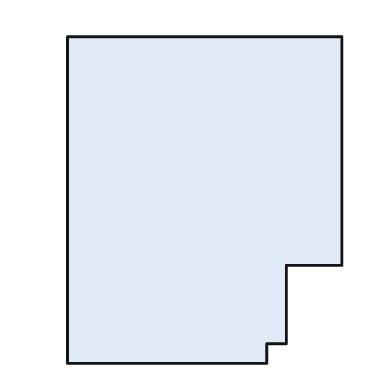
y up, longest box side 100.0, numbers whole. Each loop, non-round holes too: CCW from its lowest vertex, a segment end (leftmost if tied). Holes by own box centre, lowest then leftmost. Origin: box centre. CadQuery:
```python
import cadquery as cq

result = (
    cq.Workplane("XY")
    .moveTo(-42.0, -50.0)
    .lineTo(19.0, -50.0)
    .lineTo(19.0, -44.0)
    .lineTo(25.0, -44.0)
    .lineTo(25.0, -20.0)
    .lineTo(42.0, -20.0)
    .lineTo(42.0, 50.0)
    .lineTo(-42.0, 50.0)
    .close()
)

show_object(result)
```